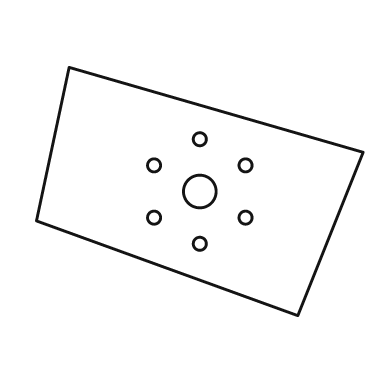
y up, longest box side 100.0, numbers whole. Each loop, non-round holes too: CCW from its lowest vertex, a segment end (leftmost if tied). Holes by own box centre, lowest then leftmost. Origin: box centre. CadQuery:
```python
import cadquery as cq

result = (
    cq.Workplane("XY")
    .moveTo(30.0, -38.0)
    .lineTo(50.0, 12.0)
    .lineTo(-40.0, 38.0)
    .lineTo(-50.0, -9.0)
    .close()
    .moveTo(0.0, -16.0)
    .circle(2.0)
    .moveTo(-14.0, -8.0)
    .circle(2.0)
    .moveTo(14.0, -8.0)
    .circle(2.0)
    .moveTo(0.0, 0.0)
    .circle(5.0)
    .moveTo(-14.0, 8.0)
    .circle(2.0)
    .moveTo(14.0, 8.0)
    .circle(2.0)
    .moveTo(0.0, 16.0)
    .circle(2.0)
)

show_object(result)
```